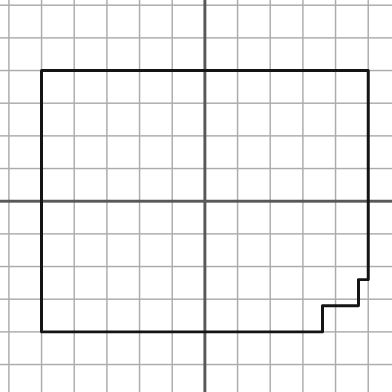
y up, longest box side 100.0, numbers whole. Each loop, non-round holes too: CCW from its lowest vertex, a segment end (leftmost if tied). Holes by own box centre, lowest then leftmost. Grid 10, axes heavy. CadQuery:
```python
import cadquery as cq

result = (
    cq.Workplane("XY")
    .moveTo(-50.0, -40.0)
    .lineTo(36.0, -40.0)
    .lineTo(36.0, -32.0)
    .lineTo(47.0, -32.0)
    .lineTo(47.0, -24.0)
    .lineTo(50.0, -24.0)
    .lineTo(50.0, 40.0)
    .lineTo(-50.0, 40.0)
    .close()
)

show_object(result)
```